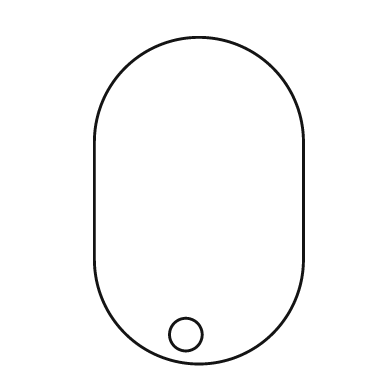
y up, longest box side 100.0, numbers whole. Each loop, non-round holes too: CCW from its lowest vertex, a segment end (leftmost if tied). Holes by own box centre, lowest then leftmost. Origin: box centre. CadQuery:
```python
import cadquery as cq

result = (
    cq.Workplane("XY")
    .moveTo(-32.0, -18.0)
    .threePointArc((0.0, -50.0), (32.0, -18.0))
    .lineTo(32.0, 18.0)
    .threePointArc((0.0, 50.0), (-32.0, 18.0))
    .close()
    .moveTo(-4.0, -41.0)
    .circle(5.0)
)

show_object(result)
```